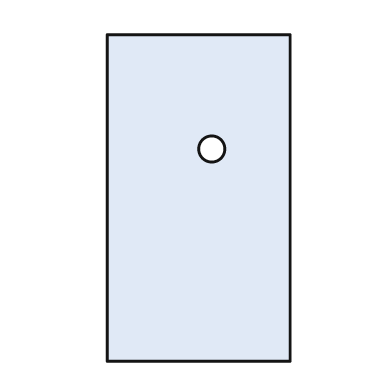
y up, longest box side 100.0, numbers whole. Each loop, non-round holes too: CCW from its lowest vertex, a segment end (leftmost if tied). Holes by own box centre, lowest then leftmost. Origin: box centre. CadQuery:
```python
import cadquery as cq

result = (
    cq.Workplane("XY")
    .moveTo(-28.0, -50.0)
    .lineTo(28.0, -50.0)
    .lineTo(28.0, 50.0)
    .lineTo(-28.0, 50.0)
    .close()
    .moveTo(4.0, 15.0)
    .circle(4.0)
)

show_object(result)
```